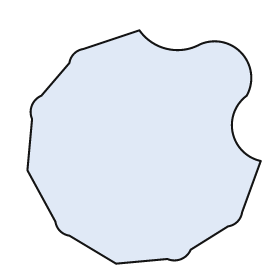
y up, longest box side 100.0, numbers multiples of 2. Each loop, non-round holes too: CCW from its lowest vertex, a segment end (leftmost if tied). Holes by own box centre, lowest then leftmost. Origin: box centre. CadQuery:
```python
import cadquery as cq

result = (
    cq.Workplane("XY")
    .moveTo(-12.0, -50.0)
    .lineTo(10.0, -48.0)
    .threePointArc((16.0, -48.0), (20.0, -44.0))
    .lineTo(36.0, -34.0)
    .threePointArc((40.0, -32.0), (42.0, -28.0))
    .lineTo(50.0, -6.0)
    .threePointArc((38.0, 6.0), (44.0, 22.0))
    .threePointArc((42.0, 40.0), (24.0, 44.0))
    .threePointArc((10.0, 42.0), (-2.0, 50.0))
    .lineTo(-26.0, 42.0)
    .threePointArc((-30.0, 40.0), (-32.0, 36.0))
    .lineTo(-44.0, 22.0)
    .threePointArc((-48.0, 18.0), (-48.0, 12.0))
    .lineTo(-50.0, -10.0)
    .lineTo(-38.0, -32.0)
    .threePointArc((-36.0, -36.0), (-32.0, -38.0))
    .close()
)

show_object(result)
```